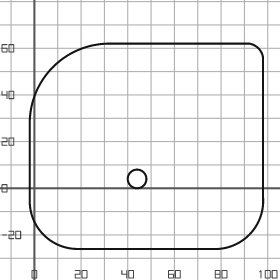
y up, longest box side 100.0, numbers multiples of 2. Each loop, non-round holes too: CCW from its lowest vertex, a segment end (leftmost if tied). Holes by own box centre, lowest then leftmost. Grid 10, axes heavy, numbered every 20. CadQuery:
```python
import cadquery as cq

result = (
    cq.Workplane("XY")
    .moveTo(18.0, -26.0)
    .lineTo(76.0, -26.0)
    .threePointArc((92.0, -20.0), (98.0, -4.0))
    .lineTo(98.0, 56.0)
    .threePointArc((96.0, 60.0), (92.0, 62.0))
    .lineTo(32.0, 62.0)
    .threePointArc((8.0, 52.0), (-2.0, 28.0))
    .lineTo(-2.0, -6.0)
    .threePointArc((4.0, -20.0), (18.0, -26.0))
    .close()
    .moveTo(44.0, 4.0)
    .circle(4.0)
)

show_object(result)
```